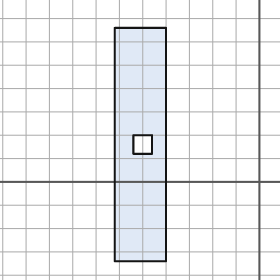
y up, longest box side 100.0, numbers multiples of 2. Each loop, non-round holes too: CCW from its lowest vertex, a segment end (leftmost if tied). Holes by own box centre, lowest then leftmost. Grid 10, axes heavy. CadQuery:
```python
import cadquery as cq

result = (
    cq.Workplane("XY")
    .moveTo(-62.0, -34.0)
    .lineTo(-40.0, -34.0)
    .lineTo(-40.0, 66.0)
    .lineTo(-62.0, 66.0)
    .close()
    .moveTo(-54.0, 12.0)
    .lineTo(-46.0, 12.0)
    .lineTo(-46.0, 20.0)
    .lineTo(-54.0, 20.0)
    .close()
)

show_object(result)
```